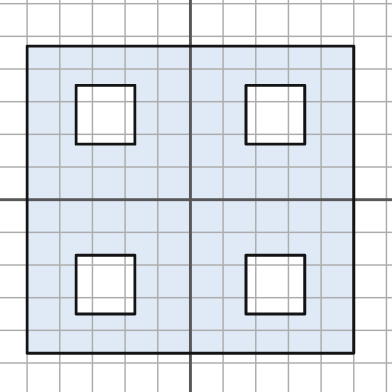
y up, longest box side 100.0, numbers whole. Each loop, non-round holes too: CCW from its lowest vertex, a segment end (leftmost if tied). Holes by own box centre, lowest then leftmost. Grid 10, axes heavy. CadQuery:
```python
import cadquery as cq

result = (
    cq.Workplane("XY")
    .moveTo(-50.0, -47.0)
    .lineTo(50.0, -47.0)
    .lineTo(50.0, 47.0)
    .lineTo(-50.0, 47.0)
    .close()
    .moveTo(-35.0, -35.0)
    .lineTo(-17.0, -35.0)
    .lineTo(-17.0, -17.0)
    .lineTo(-35.0, -17.0)
    .close()
    .moveTo(17.0, -35.0)
    .lineTo(35.0, -35.0)
    .lineTo(35.0, -17.0)
    .lineTo(17.0, -17.0)
    .close()
    .moveTo(-35.0, 17.0)
    .lineTo(-17.0, 17.0)
    .lineTo(-17.0, 35.0)
    .lineTo(-35.0, 35.0)
    .close()
    .moveTo(17.0, 17.0)
    .lineTo(35.0, 17.0)
    .lineTo(35.0, 35.0)
    .lineTo(17.0, 35.0)
    .close()
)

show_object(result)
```